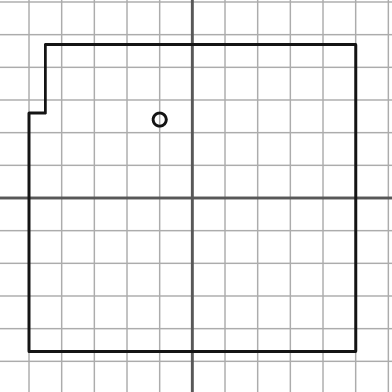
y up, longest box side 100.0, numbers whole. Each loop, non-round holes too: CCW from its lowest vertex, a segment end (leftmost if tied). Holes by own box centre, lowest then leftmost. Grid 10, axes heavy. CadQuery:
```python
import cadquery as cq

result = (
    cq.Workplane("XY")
    .moveTo(-50.0, -47.0)
    .lineTo(50.0, -47.0)
    .lineTo(50.0, 47.0)
    .lineTo(-45.0, 47.0)
    .lineTo(-45.0, 26.0)
    .lineTo(-50.0, 26.0)
    .close()
    .moveTo(-10.0, 24.0)
    .circle(2.0)
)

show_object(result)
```